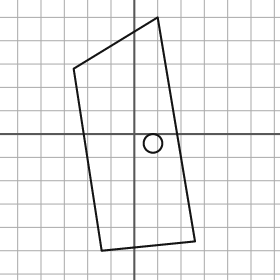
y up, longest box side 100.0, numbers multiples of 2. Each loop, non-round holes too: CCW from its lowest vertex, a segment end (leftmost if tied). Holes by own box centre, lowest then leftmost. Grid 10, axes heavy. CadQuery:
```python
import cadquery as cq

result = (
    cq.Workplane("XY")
    .moveTo(-14.0, -50.0)
    .lineTo(26.0, -46.0)
    .lineTo(10.0, 50.0)
    .lineTo(-26.0, 28.0)
    .close()
    .moveTo(8.0, -4.0)
    .circle(4.0)
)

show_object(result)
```